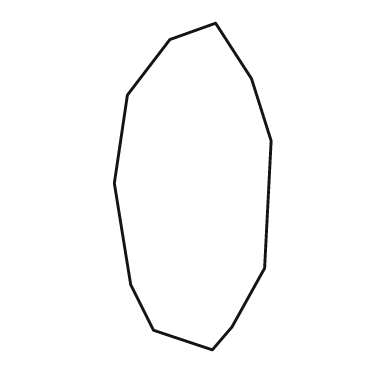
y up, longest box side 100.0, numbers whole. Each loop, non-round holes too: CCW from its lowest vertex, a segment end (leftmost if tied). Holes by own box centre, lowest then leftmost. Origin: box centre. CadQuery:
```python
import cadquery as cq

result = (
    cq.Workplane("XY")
    .moveTo(6.0, -50.0)
    .lineTo(12.0, -43.0)
    .lineTo(22.0, -25.0)
    .lineTo(24.0, 14.0)
    .lineTo(18.0, 33.0)
    .lineTo(7.0, 50.0)
    .lineTo(-7.0, 45.0)
    .lineTo(-20.0, 28.0)
    .lineTo(-24.0, 1.0)
    .lineTo(-19.0, -30.0)
    .lineTo(-12.0, -44.0)
    .close()
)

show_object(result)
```